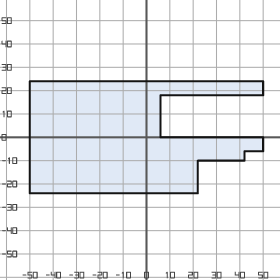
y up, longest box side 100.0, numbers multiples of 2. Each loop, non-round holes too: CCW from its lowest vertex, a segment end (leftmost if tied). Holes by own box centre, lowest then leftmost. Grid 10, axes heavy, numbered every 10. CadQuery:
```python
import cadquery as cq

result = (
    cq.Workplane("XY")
    .moveTo(-50.0, -24.0)
    .lineTo(22.0, -24.0)
    .lineTo(22.0, -10.0)
    .lineTo(42.0, -10.0)
    .lineTo(42.0, -6.0)
    .lineTo(50.0, -6.0)
    .lineTo(50.0, 0.0)
    .lineTo(6.0, 0.0)
    .lineTo(6.0, 18.0)
    .lineTo(50.0, 18.0)
    .lineTo(50.0, 24.0)
    .lineTo(-50.0, 24.0)
    .close()
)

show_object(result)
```